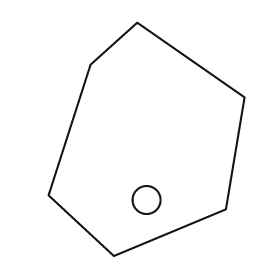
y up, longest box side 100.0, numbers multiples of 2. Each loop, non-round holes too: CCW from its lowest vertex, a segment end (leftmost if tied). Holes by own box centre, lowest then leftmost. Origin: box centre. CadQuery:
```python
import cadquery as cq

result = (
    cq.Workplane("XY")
    .moveTo(-14.0, -50.0)
    .lineTo(34.0, -30.0)
    .lineTo(42.0, 18.0)
    .lineTo(-4.0, 50.0)
    .lineTo(-24.0, 32.0)
    .lineTo(-42.0, -24.0)
    .close()
    .moveTo(0.0, -26.0)
    .circle(6.0)
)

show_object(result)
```